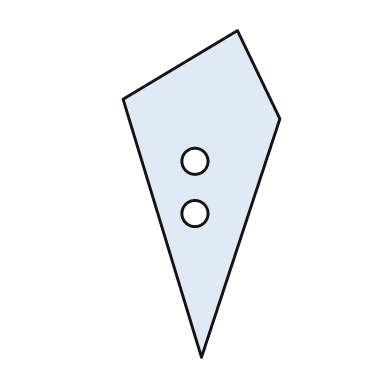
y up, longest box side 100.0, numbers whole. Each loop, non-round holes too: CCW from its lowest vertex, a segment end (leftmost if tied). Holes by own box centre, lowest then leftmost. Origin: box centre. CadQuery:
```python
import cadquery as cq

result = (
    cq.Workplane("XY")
    .moveTo(0.0, -50.0)
    .lineTo(24.0, 23.0)
    .lineTo(11.0, 50.0)
    .lineTo(-24.0, 29.0)
    .close()
    .moveTo(-2.0, -6.0)
    .circle(4.0)
    .moveTo(-2.0, 10.0)
    .circle(4.0)
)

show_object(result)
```